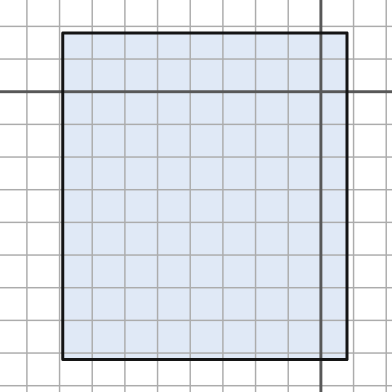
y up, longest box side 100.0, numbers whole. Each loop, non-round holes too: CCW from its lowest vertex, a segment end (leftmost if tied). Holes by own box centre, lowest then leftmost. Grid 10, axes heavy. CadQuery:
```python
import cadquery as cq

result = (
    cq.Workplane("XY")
    .moveTo(-79.0, -82.0)
    .lineTo(8.0, -82.0)
    .lineTo(8.0, 18.0)
    .lineTo(-79.0, 18.0)
    .close()
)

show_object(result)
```